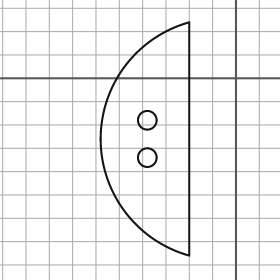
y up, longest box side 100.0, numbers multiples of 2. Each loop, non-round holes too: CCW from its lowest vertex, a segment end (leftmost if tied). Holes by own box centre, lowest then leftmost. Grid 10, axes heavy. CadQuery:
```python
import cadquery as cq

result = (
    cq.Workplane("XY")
    .moveTo(-20.0, -76.0)
    .lineTo(-20.0, 24.0)
    .threePointArc((-58.0, -26.0), (-20.0, -76.0))
    .close()
    .moveTo(-38.0, -34.0)
    .circle(4.0)
    .moveTo(-38.0, -18.0)
    .circle(4.0)
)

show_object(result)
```